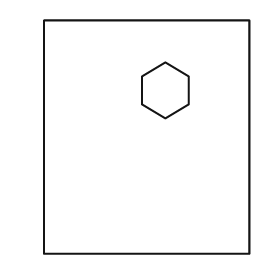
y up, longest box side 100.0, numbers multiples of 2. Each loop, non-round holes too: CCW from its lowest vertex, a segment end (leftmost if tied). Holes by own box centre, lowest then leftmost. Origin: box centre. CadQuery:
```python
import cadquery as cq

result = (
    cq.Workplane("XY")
    .moveTo(-44.0, -50.0)
    .lineTo(44.0, -50.0)
    .lineTo(44.0, 50.0)
    .lineTo(-44.0, 50.0)
    .close()
    .moveTo(8.0, 8.0)
    .lineTo(18.0, 14.0)
    .lineTo(18.0, 26.0)
    .lineTo(8.0, 32.0)
    .lineTo(-2.0, 26.0)
    .lineTo(-2.0, 14.0)
    .close()
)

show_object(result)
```